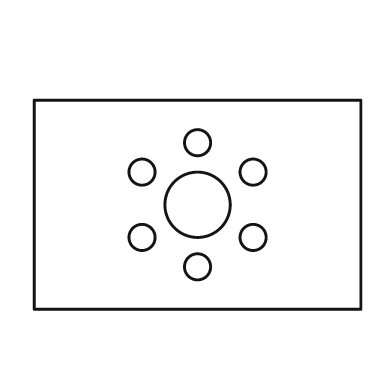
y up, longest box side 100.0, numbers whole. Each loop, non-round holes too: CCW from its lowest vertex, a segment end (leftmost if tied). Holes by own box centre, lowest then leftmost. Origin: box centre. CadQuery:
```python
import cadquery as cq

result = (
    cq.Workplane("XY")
    .moveTo(-50.0, -32.0)
    .lineTo(50.0, -32.0)
    .lineTo(50.0, 32.0)
    .lineTo(-50.0, 32.0)
    .close()
    .moveTo(0.0, -19.0)
    .circle(4.0)
    .moveTo(-17.0, -10.0)
    .circle(4.0)
    .moveTo(17.0, -10.0)
    .circle(4.0)
    .moveTo(0.0, 0.0)
    .circle(10.0)
    .moveTo(-17.0, 10.0)
    .circle(4.0)
    .moveTo(17.0, 10.0)
    .circle(4.0)
    .moveTo(0.0, 19.0)
    .circle(4.0)
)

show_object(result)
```